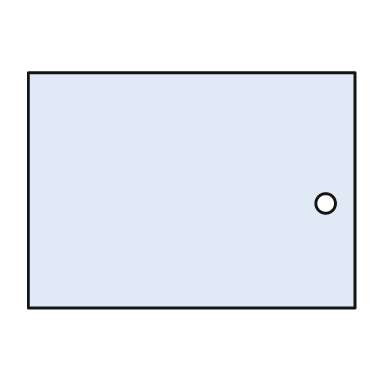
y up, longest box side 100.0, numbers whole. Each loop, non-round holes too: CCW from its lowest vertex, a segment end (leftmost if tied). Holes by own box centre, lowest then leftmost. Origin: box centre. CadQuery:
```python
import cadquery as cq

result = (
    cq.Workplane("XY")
    .moveTo(-50.0, -36.0)
    .lineTo(50.0, -36.0)
    .lineTo(50.0, 36.0)
    .lineTo(-50.0, 36.0)
    .close()
    .moveTo(41.0, -4.0)
    .circle(3.0)
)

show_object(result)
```